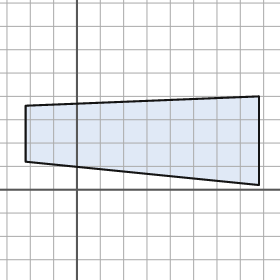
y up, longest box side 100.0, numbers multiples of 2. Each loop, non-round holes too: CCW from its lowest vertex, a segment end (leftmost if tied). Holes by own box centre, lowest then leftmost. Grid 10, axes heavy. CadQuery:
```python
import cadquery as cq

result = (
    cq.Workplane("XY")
    .moveTo(78.0, 2.0)
    .lineTo(78.0, 40.0)
    .lineTo(-22.0, 36.0)
    .lineTo(-22.0, 12.0)
    .close()
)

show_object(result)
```